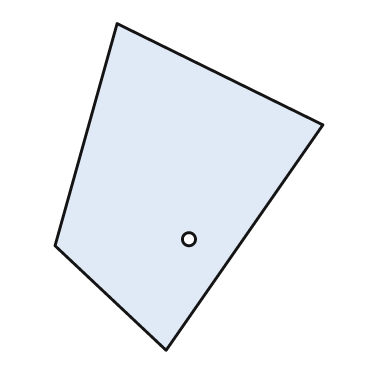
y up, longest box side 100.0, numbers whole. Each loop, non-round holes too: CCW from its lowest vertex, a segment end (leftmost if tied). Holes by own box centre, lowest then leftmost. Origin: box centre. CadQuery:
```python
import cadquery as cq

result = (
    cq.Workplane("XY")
    .moveTo(-7.0, -50.0)
    .lineTo(41.0, 19.0)
    .lineTo(-22.0, 50.0)
    .lineTo(-41.0, -18.0)
    .close()
    .moveTo(0.0, -16.0)
    .circle(2.0)
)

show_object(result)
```